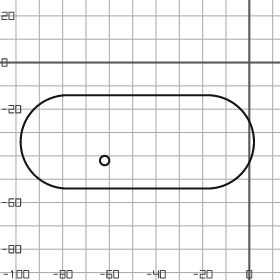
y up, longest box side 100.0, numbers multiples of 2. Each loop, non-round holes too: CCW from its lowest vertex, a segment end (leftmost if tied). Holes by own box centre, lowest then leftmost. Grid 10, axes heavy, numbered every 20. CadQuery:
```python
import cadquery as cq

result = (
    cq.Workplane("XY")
    .moveTo(-78.0, -54.0)
    .lineTo(-18.0, -54.0)
    .threePointArc((2.0, -34.0), (-18.0, -14.0))
    .lineTo(-78.0, -14.0)
    .threePointArc((-98.0, -34.0), (-78.0, -54.0))
    .close()
    .moveTo(-62.0, -42.0)
    .circle(2.0)
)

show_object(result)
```